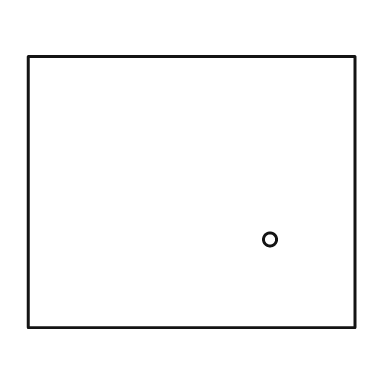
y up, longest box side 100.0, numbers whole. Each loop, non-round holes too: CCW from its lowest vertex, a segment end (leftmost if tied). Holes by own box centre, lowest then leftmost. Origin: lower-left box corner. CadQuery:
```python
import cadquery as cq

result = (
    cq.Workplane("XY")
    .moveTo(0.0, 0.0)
    .lineTo(100.0, 0.0)
    .lineTo(100.0, 83.0)
    .lineTo(0.0, 83.0)
    .close()
    .moveTo(74.0, 27.0)
    .circle(2.0)
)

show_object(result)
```